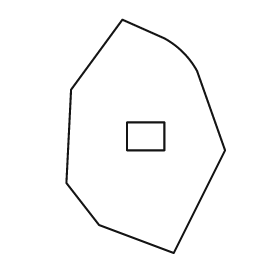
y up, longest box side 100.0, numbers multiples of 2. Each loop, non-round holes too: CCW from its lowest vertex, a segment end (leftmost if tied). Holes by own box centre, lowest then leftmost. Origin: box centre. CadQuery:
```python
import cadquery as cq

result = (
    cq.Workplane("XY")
    .moveTo(12.0, -50.0)
    .lineTo(34.0, -6.0)
    .lineTo(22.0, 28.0)
    .threePointArc((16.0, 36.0), (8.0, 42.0))
    .lineTo(-10.0, 50.0)
    .lineTo(-32.0, 20.0)
    .lineTo(-34.0, -20.0)
    .lineTo(-20.0, -38.0)
    .close()
    .moveTo(-8.0, -6.0)
    .lineTo(8.0, -6.0)
    .lineTo(8.0, 6.0)
    .lineTo(-8.0, 6.0)
    .close()
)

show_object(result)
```